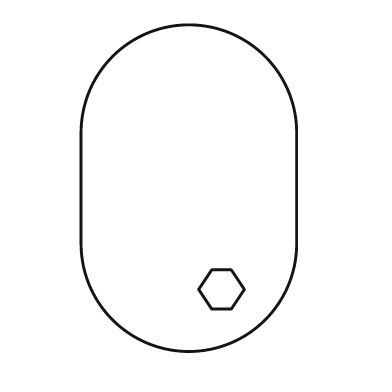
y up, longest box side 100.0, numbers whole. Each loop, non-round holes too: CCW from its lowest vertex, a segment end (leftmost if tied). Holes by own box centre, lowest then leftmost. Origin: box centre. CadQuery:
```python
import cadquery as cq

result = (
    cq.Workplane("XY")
    .moveTo(-33.0, -17.0)
    .threePointArc((0.0, -50.0), (33.0, -17.0))
    .lineTo(33.0, 17.0)
    .threePointArc((0.0, 50.0), (-33.0, 17.0))
    .close()
    .moveTo(7.0, -37.0)
    .lineTo(13.0, -37.0)
    .lineTo(17.0, -31.0)
    .lineTo(13.0, -25.0)
    .lineTo(7.0, -25.0)
    .lineTo(3.0, -31.0)
    .close()
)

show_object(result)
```